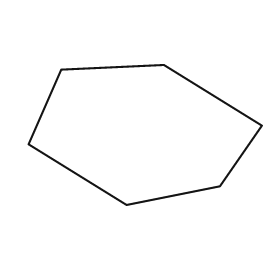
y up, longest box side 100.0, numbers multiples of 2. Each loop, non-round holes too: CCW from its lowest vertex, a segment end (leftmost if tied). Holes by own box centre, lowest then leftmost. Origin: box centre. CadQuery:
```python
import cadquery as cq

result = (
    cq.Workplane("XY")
    .moveTo(-8.0, -30.0)
    .lineTo(32.0, -22.0)
    .lineTo(50.0, 4.0)
    .lineTo(8.0, 30.0)
    .lineTo(-36.0, 28.0)
    .lineTo(-50.0, -4.0)
    .close()
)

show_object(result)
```